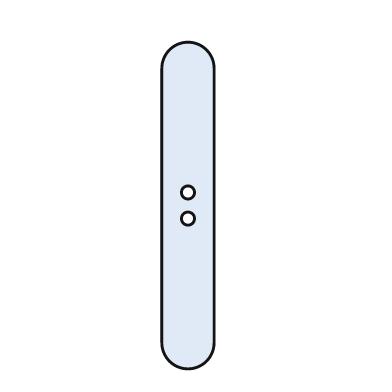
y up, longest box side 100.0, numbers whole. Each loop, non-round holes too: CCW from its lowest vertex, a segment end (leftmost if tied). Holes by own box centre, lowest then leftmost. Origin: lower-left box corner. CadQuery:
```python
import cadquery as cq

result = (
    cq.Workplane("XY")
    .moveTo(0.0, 8.0)
    .threePointArc((8.0, 0.0), (16.0, 8.0))
    .lineTo(16.0, 92.0)
    .threePointArc((8.0, 100.0), (0.0, 92.0))
    .close()
    .moveTo(8.0, 46.0)
    .circle(2.0)
    .moveTo(8.0, 54.0)
    .circle(2.0)
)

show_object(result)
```